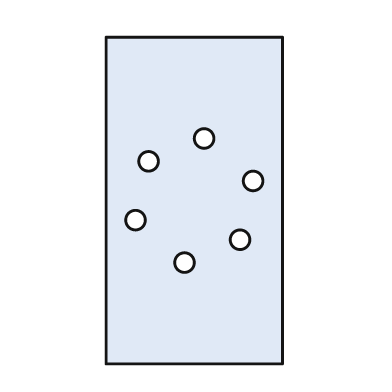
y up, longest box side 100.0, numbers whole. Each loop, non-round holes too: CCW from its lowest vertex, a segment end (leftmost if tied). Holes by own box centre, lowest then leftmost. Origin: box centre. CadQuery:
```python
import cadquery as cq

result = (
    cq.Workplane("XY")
    .moveTo(-27.0, -50.0)
    .lineTo(27.0, -50.0)
    .lineTo(27.0, 50.0)
    .lineTo(-27.0, 50.0)
    .close()
    .moveTo(-3.0, -19.0)
    .circle(3.0)
    .moveTo(14.0, -12.0)
    .circle(3.0)
    .moveTo(-18.0, -6.0)
    .circle(3.0)
    .moveTo(18.0, 6.0)
    .circle(3.0)
    .moveTo(-14.0, 12.0)
    .circle(3.0)
    .moveTo(3.0, 19.0)
    .circle(3.0)
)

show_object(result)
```